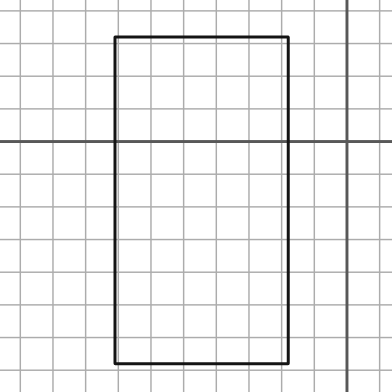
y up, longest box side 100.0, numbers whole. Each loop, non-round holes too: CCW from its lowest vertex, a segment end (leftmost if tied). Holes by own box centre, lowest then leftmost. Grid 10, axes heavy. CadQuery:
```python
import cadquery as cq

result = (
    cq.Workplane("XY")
    .moveTo(-71.0, -68.0)
    .lineTo(-18.0, -68.0)
    .lineTo(-18.0, 32.0)
    .lineTo(-71.0, 32.0)
    .close()
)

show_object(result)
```